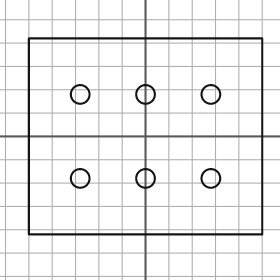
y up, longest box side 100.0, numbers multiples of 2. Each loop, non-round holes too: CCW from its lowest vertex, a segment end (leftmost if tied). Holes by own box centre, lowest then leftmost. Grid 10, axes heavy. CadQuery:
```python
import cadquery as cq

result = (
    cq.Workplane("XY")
    .moveTo(-50.0, -42.0)
    .lineTo(50.0, -42.0)
    .lineTo(50.0, 42.0)
    .lineTo(-50.0, 42.0)
    .close()
    .moveTo(-28.0, -18.0)
    .circle(4.0)
    .moveTo(0.0, -18.0)
    .circle(4.0)
    .moveTo(28.0, -18.0)
    .circle(4.0)
    .moveTo(-28.0, 18.0)
    .circle(4.0)
    .moveTo(0.0, 18.0)
    .circle(4.0)
    .moveTo(28.0, 18.0)
    .circle(4.0)
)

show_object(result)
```